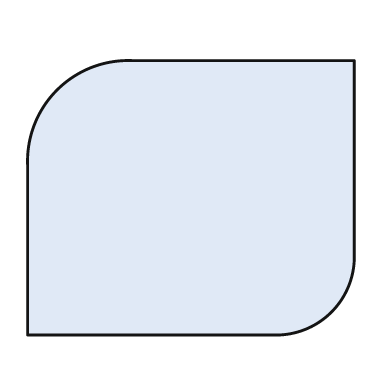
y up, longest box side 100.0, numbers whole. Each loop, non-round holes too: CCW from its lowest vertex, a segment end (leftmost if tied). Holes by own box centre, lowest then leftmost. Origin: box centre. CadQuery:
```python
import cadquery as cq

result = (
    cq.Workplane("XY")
    .moveTo(-50.0, -42.0)
    .lineTo(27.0, -42.0)
    .threePointArc((43.0, -35.0), (50.0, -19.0))
    .lineTo(50.0, 42.0)
    .lineTo(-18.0, 42.0)
    .threePointArc((-41.0, 33.0), (-50.0, 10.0))
    .close()
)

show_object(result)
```